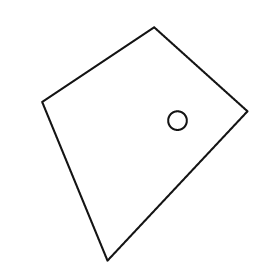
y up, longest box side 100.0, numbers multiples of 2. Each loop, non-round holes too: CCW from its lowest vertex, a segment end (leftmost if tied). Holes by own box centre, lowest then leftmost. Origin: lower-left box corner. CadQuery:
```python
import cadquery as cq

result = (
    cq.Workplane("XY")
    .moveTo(28.0, 0.0)
    .lineTo(88.0, 64.0)
    .lineTo(48.0, 100.0)
    .lineTo(0.0, 68.0)
    .close()
    .moveTo(58.0, 60.0)
    .circle(4.0)
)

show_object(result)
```